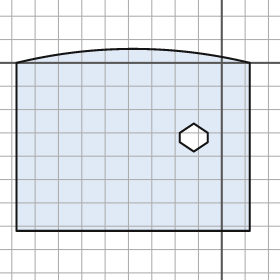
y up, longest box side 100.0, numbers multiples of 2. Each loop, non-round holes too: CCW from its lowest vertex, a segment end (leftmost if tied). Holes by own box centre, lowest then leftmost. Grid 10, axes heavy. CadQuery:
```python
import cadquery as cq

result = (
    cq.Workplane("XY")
    .moveTo(-88.0, -72.0)
    .lineTo(12.0, -72.0)
    .lineTo(12.0, 0.0)
    .threePointArc((-38.0, 6.0), (-88.0, 0.0))
    .close()
    .moveTo(-12.0, -38.0)
    .lineTo(-6.0, -34.0)
    .lineTo(-6.0, -30.0)
    .lineTo(-12.0, -26.0)
    .lineTo(-18.0, -30.0)
    .lineTo(-18.0, -34.0)
    .close()
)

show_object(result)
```